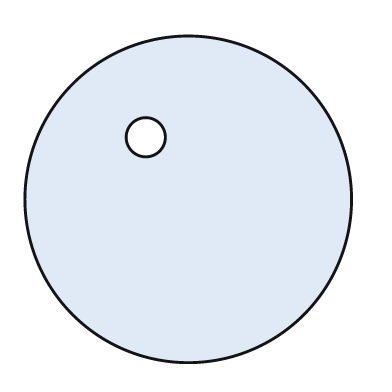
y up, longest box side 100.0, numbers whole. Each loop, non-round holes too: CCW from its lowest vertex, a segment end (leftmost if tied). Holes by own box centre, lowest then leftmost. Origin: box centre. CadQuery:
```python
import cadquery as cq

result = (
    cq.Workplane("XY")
    .moveTo(0.0, 0.0)
    .circle(50.0)
    .moveTo(-13.0, 19.0)
    .circle(6.0)
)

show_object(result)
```